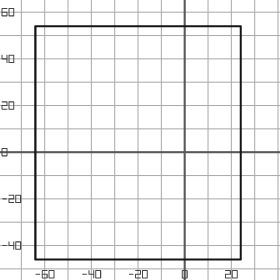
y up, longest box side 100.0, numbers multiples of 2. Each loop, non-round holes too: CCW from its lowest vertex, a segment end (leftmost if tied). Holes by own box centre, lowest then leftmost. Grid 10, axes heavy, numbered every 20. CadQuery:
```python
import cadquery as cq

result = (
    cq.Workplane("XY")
    .moveTo(-64.0, -46.0)
    .lineTo(24.0, -46.0)
    .lineTo(24.0, 54.0)
    .lineTo(-64.0, 54.0)
    .close()
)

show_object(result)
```